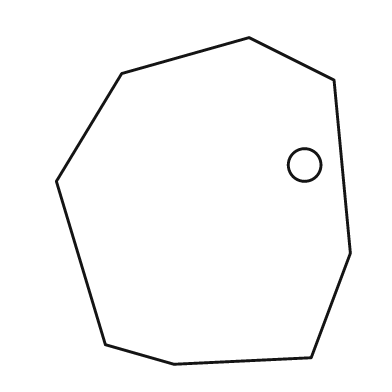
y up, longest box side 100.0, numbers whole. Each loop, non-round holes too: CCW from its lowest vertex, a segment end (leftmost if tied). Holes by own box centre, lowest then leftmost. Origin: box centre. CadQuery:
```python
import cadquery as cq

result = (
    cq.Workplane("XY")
    .moveTo(-9.0, -50.0)
    .lineTo(33.0, -48.0)
    .lineTo(45.0, -16.0)
    .lineTo(40.0, 37.0)
    .lineTo(14.0, 50.0)
    .lineTo(-25.0, 39.0)
    .lineTo(-45.0, 6.0)
    .lineTo(-30.0, -44.0)
    .close()
    .moveTo(31.0, 11.0)
    .circle(5.0)
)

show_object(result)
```